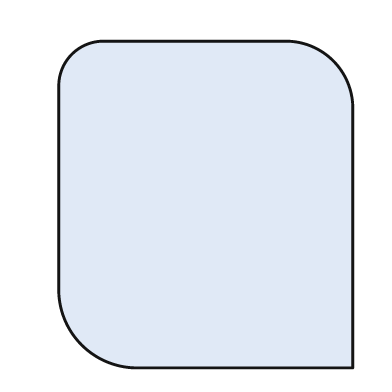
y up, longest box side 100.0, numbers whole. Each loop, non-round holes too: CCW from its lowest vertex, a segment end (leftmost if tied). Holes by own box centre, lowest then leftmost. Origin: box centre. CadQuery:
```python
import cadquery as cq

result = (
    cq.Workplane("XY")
    .moveTo(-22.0, -50.0)
    .lineTo(45.0, -50.0)
    .lineTo(45.0, 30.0)
    .threePointArc((39.0, 44.0), (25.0, 50.0))
    .lineTo(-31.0, 50.0)
    .threePointArc((-41.0, 46.0), (-45.0, 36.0))
    .lineTo(-45.0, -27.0)
    .threePointArc((-38.0, -43.0), (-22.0, -50.0))
    .close()
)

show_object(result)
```